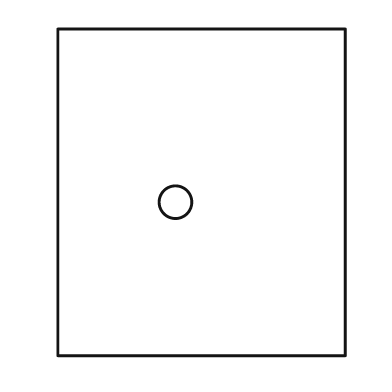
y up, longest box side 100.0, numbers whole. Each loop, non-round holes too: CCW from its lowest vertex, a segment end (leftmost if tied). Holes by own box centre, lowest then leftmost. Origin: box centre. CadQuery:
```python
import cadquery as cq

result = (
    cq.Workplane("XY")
    .moveTo(-44.0, -50.0)
    .lineTo(44.0, -50.0)
    .lineTo(44.0, 50.0)
    .lineTo(-44.0, 50.0)
    .close()
    .moveTo(-8.0, -3.0)
    .circle(5.0)
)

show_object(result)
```